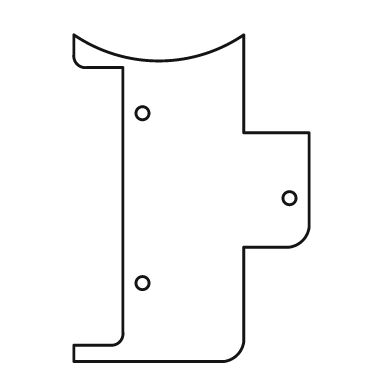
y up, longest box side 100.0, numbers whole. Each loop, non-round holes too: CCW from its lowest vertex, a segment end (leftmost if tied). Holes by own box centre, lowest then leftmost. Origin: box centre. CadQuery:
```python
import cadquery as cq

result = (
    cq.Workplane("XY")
    .moveTo(-36.0, -50.0)
    .lineTo(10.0, -50.0)
    .threePointArc((14.0, -48.0), (16.0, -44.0))
    .lineTo(16.0, -15.0)
    .lineTo(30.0, -15.0)
    .threePointArc((34.0, -13.0), (36.0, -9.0))
    .lineTo(36.0, 20.0)
    .lineTo(16.0, 20.0)
    .lineTo(16.0, 50.0)
    .threePointArc((-10.0, 42.0), (-36.0, 50.0))
    .lineTo(-36.0, 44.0)
    .threePointArc((-35.0, 41.0), (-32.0, 40.0))
    .lineTo(-21.0, 40.0)
    .lineTo(-21.0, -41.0)
    .threePointArc((-22.0, -44.0), (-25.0, -45.0))
    .lineTo(-36.0, -45.0)
    .close()
    .moveTo(-15.0, -26.0)
    .circle(2.0)
    .moveTo(30.0, 0.0)
    .circle(2.0)
    .moveTo(-15.0, 26.0)
    .circle(2.0)
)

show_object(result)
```